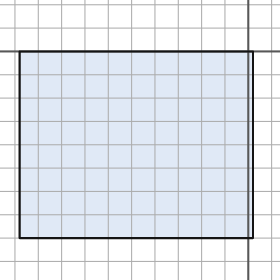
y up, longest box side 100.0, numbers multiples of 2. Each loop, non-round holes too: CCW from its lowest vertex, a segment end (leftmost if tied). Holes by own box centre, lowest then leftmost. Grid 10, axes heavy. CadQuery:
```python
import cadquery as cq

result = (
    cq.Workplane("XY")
    .moveTo(-98.0, -80.0)
    .lineTo(2.0, -80.0)
    .lineTo(2.0, 0.0)
    .lineTo(-98.0, 0.0)
    .close()
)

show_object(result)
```